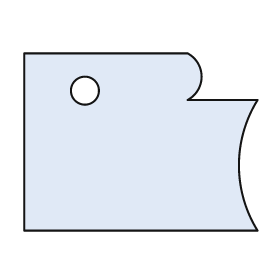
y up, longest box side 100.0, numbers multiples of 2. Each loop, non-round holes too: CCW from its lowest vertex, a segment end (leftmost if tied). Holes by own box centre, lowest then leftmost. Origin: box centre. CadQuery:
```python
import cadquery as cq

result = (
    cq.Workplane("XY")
    .moveTo(-50.0, -38.0)
    .lineTo(50.0, -38.0)
    .threePointArc((42.0, -10.0), (50.0, 18.0))
    .lineTo(20.0, 18.0)
    .threePointArc((26.0, 28.0), (20.0, 38.0))
    .lineTo(-50.0, 38.0)
    .close()
    .moveTo(-24.0, 22.0)
    .circle(6.0)
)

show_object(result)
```